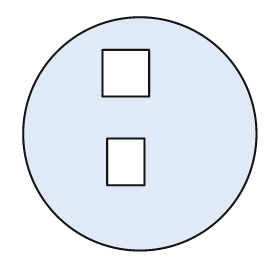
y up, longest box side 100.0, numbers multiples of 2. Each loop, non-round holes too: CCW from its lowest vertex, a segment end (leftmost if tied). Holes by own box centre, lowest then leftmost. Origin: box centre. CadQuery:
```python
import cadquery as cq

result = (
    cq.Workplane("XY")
    .moveTo(0.0, 0.0)
    .circle(50.0)
    .moveTo(-14.0, -22.0)
    .lineTo(2.0, -22.0)
    .lineTo(2.0, -2.0)
    .lineTo(-14.0, -2.0)
    .close()
    .moveTo(-16.0, 16.0)
    .lineTo(4.0, 16.0)
    .lineTo(4.0, 36.0)
    .lineTo(-16.0, 36.0)
    .close()
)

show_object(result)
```